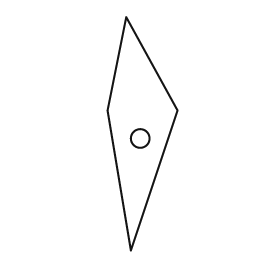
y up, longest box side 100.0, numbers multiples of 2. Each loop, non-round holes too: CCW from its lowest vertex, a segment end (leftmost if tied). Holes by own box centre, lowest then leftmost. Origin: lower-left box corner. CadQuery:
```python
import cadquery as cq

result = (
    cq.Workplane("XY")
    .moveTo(10.0, 0.0)
    .lineTo(30.0, 60.0)
    .lineTo(8.0, 100.0)
    .lineTo(0.0, 60.0)
    .close()
    .moveTo(14.0, 48.0)
    .circle(4.0)
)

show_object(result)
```